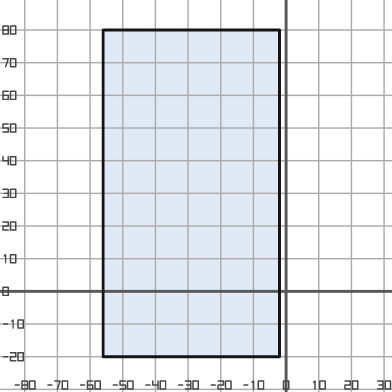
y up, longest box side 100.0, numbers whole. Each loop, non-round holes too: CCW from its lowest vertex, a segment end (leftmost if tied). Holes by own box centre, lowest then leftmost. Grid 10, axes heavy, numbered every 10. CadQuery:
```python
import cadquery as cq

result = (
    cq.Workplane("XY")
    .moveTo(-56.0, -20.0)
    .lineTo(-2.0, -20.0)
    .lineTo(-2.0, 80.0)
    .lineTo(-56.0, 80.0)
    .close()
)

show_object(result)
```